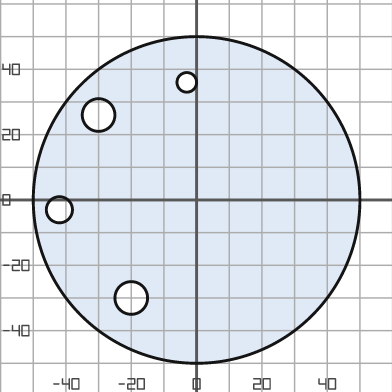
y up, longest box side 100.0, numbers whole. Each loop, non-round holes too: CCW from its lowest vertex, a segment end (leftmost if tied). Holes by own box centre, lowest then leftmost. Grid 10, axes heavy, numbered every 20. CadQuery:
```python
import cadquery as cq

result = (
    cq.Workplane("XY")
    .moveTo(0.0, 0.0)
    .circle(50.0)
    .moveTo(-20.0, -30.0)
    .circle(5.0)
    .moveTo(-42.0, -3.0)
    .circle(4.0)
    .moveTo(-30.0, 26.0)
    .circle(5.0)
    .moveTo(-3.0, 36.0)
    .circle(3.0)
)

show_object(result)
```